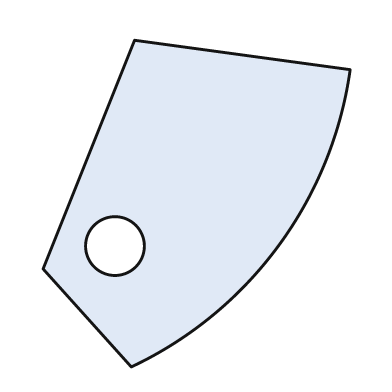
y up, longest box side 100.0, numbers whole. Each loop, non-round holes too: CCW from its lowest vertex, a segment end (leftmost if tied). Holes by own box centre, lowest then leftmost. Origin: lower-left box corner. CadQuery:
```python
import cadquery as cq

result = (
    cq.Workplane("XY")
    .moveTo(27.0, 0.0)
    .threePointArc((72.0, 37.0), (94.0, 91.0))
    .lineTo(28.0, 100.0)
    .lineTo(0.0, 30.0)
    .close()
    .moveTo(22.0, 37.0)
    .circle(9.0)
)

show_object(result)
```